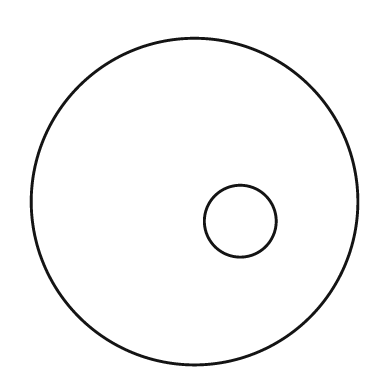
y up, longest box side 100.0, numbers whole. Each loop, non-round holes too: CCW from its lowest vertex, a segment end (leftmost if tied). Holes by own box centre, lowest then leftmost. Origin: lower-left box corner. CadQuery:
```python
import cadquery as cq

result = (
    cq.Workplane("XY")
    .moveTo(50.0, 50.0)
    .circle(50.0)
    .moveTo(64.0, 44.0)
    .circle(11.0)
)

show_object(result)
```